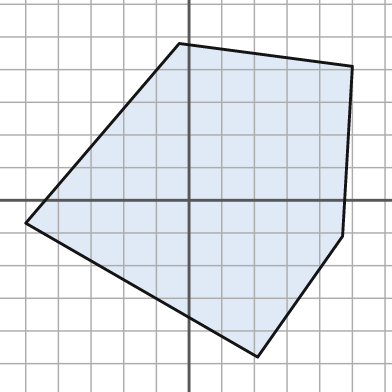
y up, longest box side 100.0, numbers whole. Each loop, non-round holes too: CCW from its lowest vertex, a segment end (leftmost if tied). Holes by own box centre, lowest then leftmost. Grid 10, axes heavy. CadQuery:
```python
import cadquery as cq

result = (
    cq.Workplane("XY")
    .moveTo(21.0, -48.0)
    .lineTo(47.0, -11.0)
    .lineTo(50.0, 41.0)
    .lineTo(-3.0, 48.0)
    .lineTo(-50.0, -7.0)
    .close()
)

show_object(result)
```